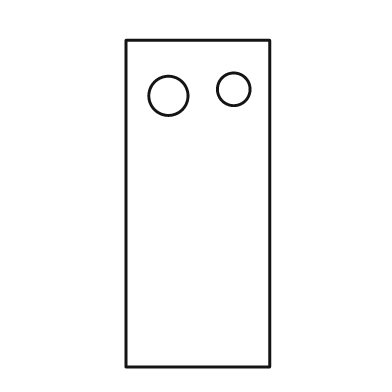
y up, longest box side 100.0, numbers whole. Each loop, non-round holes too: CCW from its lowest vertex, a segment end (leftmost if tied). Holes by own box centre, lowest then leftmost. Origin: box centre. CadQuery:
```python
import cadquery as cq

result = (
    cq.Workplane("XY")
    .moveTo(-22.0, -50.0)
    .lineTo(22.0, -50.0)
    .lineTo(22.0, 50.0)
    .lineTo(-22.0, 50.0)
    .close()
    .moveTo(-9.0, 33.0)
    .circle(6.0)
    .moveTo(11.0, 35.0)
    .circle(5.0)
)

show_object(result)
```